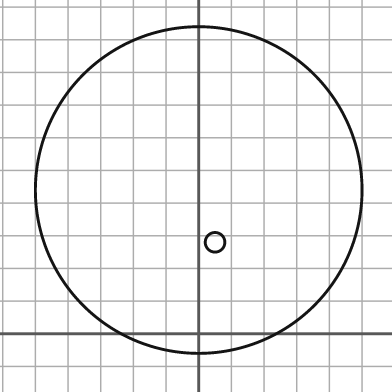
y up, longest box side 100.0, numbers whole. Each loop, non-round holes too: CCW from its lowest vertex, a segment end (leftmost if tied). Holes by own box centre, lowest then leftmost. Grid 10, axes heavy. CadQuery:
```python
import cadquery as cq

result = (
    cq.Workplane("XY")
    .moveTo(0.0, 44.0)
    .circle(50.0)
    .moveTo(5.0, 28.0)
    .circle(3.0)
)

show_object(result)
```